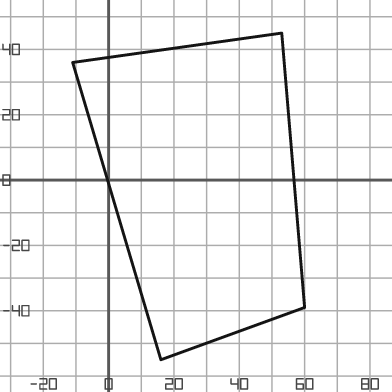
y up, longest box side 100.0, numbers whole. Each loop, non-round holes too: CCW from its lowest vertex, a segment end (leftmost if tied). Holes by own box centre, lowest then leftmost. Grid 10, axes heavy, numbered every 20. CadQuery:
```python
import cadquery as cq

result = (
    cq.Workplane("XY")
    .moveTo(16.0, -55.0)
    .lineTo(60.0, -39.0)
    .lineTo(53.0, 45.0)
    .lineTo(-11.0, 36.0)
    .close()
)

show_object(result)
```